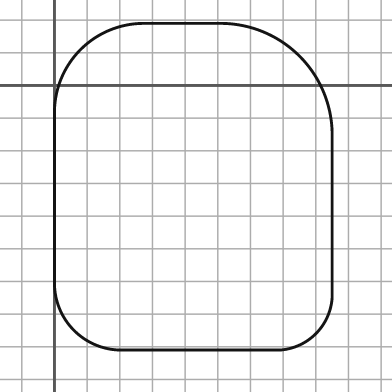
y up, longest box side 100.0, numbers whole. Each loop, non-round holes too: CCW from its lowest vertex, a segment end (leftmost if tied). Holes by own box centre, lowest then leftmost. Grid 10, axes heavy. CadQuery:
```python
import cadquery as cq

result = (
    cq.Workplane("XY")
    .moveTo(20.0, -81.0)
    .lineTo(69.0, -81.0)
    .threePointArc((80.0, -76.0), (85.0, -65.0))
    .lineTo(85.0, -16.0)
    .threePointArc((75.0, 9.0), (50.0, 19.0))
    .lineTo(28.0, 19.0)
    .threePointArc((8.0, 11.0), (0.0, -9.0))
    .lineTo(0.0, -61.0)
    .threePointArc((6.0, -75.0), (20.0, -81.0))
    .close()
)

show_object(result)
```